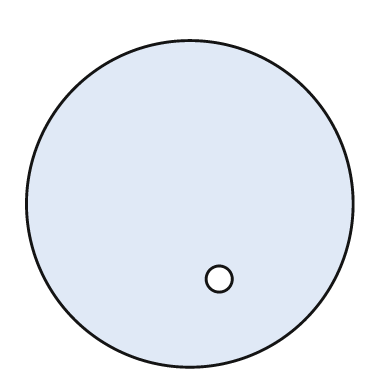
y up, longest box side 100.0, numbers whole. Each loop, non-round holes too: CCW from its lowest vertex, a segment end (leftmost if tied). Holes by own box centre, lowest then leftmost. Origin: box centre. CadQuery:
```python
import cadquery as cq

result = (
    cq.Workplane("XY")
    .moveTo(0.0, 0.0)
    .circle(50.0)
    .moveTo(9.0, -23.0)
    .circle(4.0)
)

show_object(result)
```